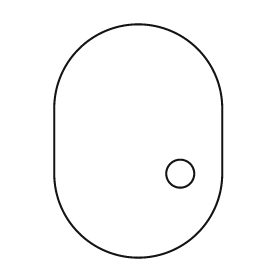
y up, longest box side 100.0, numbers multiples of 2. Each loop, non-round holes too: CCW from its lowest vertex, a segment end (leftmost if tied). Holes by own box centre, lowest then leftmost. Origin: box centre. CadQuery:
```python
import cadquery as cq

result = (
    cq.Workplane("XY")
    .moveTo(-36.0, -14.0)
    .threePointArc((0.0, -50.0), (36.0, -14.0))
    .lineTo(36.0, 14.0)
    .threePointArc((0.0, 50.0), (-36.0, 14.0))
    .close()
    .moveTo(18.0, -14.0)
    .circle(6.0)
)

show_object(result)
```